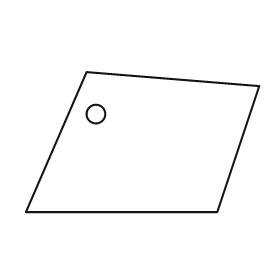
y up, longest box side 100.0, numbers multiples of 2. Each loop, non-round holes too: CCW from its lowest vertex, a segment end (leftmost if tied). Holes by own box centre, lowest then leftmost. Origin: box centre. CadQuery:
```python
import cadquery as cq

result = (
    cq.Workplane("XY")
    .moveTo(-50.0, -30.0)
    .lineTo(32.0, -30.0)
    .lineTo(50.0, 24.0)
    .lineTo(-24.0, 30.0)
    .close()
    .moveTo(-20.0, 12.0)
    .circle(4.0)
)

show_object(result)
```